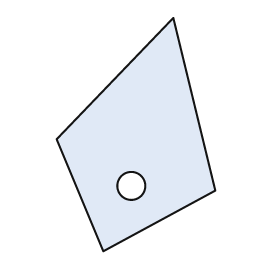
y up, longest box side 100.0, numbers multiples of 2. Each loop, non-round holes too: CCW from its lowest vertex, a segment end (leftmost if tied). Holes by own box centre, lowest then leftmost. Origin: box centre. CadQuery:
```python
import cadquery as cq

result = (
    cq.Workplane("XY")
    .moveTo(-14.0, -50.0)
    .lineTo(34.0, -24.0)
    .lineTo(16.0, 50.0)
    .lineTo(-34.0, -2.0)
    .close()
    .moveTo(-2.0, -22.0)
    .circle(6.0)
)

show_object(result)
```